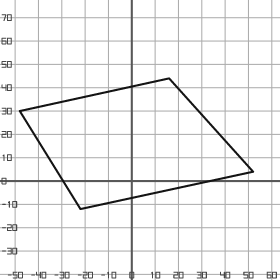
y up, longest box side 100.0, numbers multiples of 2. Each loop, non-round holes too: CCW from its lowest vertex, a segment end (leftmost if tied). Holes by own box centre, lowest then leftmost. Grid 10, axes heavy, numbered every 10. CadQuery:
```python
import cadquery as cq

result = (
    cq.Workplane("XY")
    .moveTo(-22.0, -12.0)
    .lineTo(52.0, 4.0)
    .lineTo(16.0, 44.0)
    .lineTo(-48.0, 30.0)
    .close()
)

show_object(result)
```